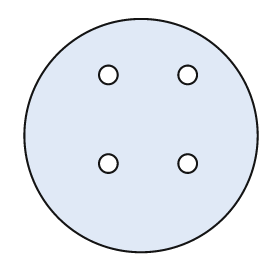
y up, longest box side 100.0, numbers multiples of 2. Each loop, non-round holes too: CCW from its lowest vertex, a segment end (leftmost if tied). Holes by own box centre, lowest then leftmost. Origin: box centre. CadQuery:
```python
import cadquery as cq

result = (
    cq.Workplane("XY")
    .moveTo(0.0, 0.0)
    .circle(50.0)
    .moveTo(-14.0, -12.0)
    .circle(4.0)
    .moveTo(20.0, -12.0)
    .circle(4.0)
    .moveTo(-14.0, 26.0)
    .circle(4.0)
    .moveTo(20.0, 26.0)
    .circle(4.0)
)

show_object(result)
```